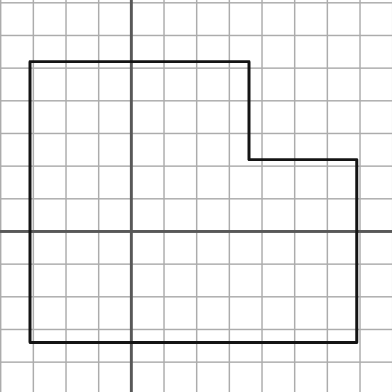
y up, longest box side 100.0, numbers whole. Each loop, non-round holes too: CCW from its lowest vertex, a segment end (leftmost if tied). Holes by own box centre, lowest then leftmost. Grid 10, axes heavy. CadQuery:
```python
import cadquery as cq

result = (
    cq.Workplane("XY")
    .moveTo(-31.0, -34.0)
    .lineTo(69.0, -34.0)
    .lineTo(69.0, 22.0)
    .lineTo(36.0, 22.0)
    .lineTo(36.0, 52.0)
    .lineTo(-31.0, 52.0)
    .close()
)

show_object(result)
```